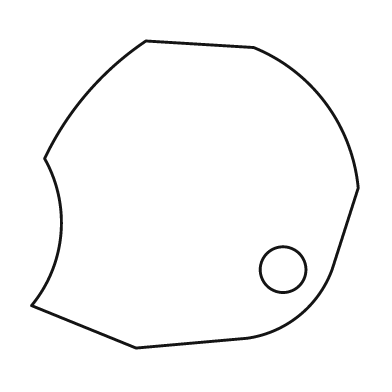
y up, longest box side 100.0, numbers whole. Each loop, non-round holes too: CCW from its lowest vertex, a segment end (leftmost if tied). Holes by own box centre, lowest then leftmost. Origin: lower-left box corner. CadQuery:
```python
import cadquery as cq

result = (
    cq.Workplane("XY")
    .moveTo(32.0, 0.0)
    .lineTo(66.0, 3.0)
    .threePointArc((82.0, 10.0), (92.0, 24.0))
    .lineTo(100.0, 49.0)
    .threePointArc((90.0, 75.0), (68.0, 92.0))
    .lineTo(35.0, 94.0)
    .threePointArc((17.0, 78.0), (4.0, 58.0))
    .threePointArc((9.0, 35.0), (0.0, 13.0))
    .close()
    .moveTo(77.0, 24.0)
    .circle(7.0)
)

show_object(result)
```